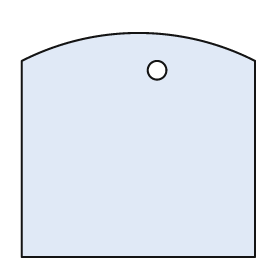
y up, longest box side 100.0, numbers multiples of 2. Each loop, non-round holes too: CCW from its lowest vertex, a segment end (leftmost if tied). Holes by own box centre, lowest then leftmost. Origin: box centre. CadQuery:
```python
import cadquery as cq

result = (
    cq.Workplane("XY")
    .moveTo(-50.0, -48.0)
    .lineTo(50.0, -48.0)
    .lineTo(50.0, 36.0)
    .threePointArc((0.0, 48.0), (-50.0, 36.0))
    .close()
    .moveTo(8.0, 32.0)
    .circle(4.0)
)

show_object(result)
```